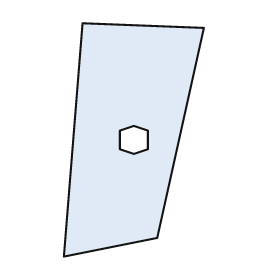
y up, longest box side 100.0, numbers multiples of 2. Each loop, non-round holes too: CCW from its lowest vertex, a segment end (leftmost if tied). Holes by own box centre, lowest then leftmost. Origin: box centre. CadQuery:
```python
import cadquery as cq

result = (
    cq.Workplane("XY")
    .moveTo(-30.0, -50.0)
    .lineTo(10.0, -42.0)
    .lineTo(30.0, 48.0)
    .lineTo(-22.0, 50.0)
    .close()
    .moveTo(0.0, -6.0)
    .lineTo(6.0, -4.0)
    .lineTo(6.0, 4.0)
    .lineTo(0.0, 6.0)
    .lineTo(-6.0, 4.0)
    .lineTo(-6.0, -4.0)
    .close()
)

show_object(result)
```